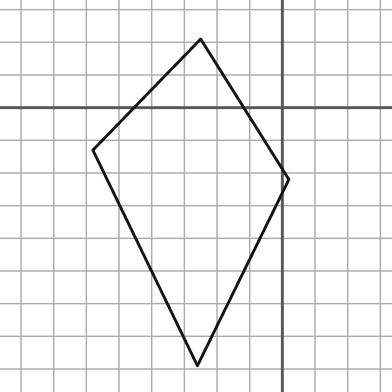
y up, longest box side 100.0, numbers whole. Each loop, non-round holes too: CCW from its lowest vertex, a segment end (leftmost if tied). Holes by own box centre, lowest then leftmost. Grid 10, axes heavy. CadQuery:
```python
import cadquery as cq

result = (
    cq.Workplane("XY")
    .moveTo(-26.0, -79.0)
    .lineTo(2.0, -22.0)
    .lineTo(-25.0, 21.0)
    .lineTo(-58.0, -13.0)
    .close()
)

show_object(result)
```